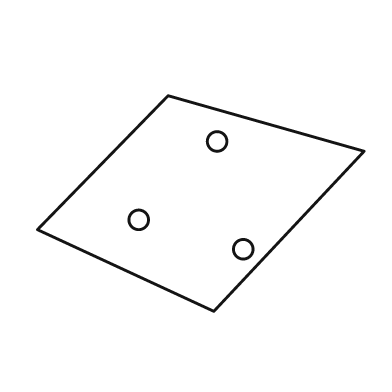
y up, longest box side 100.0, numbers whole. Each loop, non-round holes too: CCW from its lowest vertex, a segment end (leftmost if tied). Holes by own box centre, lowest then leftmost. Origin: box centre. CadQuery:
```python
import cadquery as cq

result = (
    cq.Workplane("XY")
    .moveTo(4.0, -33.0)
    .lineTo(50.0, 16.0)
    .lineTo(-10.0, 33.0)
    .lineTo(-50.0, -8.0)
    .close()
    .moveTo(13.0, -14.0)
    .circle(3.0)
    .moveTo(-19.0, -5.0)
    .circle(3.0)
    .moveTo(5.0, 19.0)
    .circle(3.0)
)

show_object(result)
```